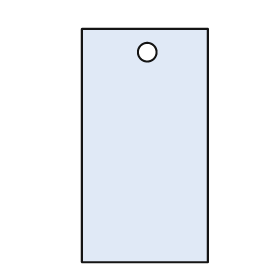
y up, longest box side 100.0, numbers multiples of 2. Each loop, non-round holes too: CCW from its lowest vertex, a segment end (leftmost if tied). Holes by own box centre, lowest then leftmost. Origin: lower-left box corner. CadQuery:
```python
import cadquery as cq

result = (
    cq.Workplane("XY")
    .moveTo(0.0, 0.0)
    .lineTo(54.0, 0.0)
    .lineTo(54.0, 100.0)
    .lineTo(0.0, 100.0)
    .close()
    .moveTo(28.0, 90.0)
    .circle(4.0)
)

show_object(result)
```